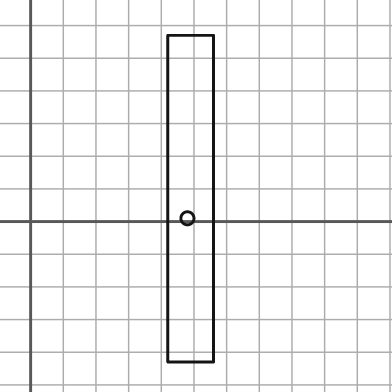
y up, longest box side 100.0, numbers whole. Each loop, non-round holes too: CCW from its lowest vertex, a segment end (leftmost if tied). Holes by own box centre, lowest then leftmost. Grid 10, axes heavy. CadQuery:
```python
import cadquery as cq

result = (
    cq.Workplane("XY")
    .moveTo(42.0, -43.0)
    .lineTo(56.0, -43.0)
    .lineTo(56.0, 57.0)
    .lineTo(42.0, 57.0)
    .close()
    .moveTo(48.0, 1.0)
    .circle(2.0)
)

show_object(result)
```